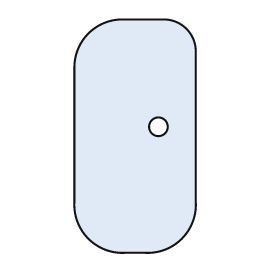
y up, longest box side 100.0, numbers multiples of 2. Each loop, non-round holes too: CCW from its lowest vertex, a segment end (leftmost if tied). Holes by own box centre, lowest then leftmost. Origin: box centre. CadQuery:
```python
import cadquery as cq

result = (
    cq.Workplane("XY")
    .moveTo(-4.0, -50.0)
    .lineTo(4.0, -50.0)
    .threePointArc((20.0, -44.0), (26.0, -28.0))
    .lineTo(26.0, 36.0)
    .threePointArc((22.0, 46.0), (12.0, 50.0))
    .lineTo(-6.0, 50.0)
    .threePointArc((-20.0, 44.0), (-26.0, 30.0))
    .lineTo(-26.0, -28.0)
    .threePointArc((-20.0, -44.0), (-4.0, -50.0))
    .close()
    .moveTo(10.0, 4.0)
    .circle(4.0)
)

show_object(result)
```